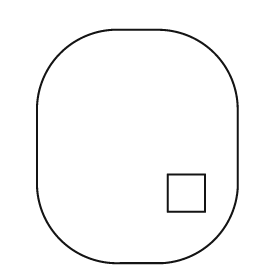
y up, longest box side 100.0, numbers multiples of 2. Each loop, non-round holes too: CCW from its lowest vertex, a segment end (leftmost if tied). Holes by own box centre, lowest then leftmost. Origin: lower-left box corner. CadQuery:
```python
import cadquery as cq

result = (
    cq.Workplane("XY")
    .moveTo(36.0, 0.0)
    .lineTo(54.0, 0.0)
    .threePointArc((76.0, 10.0), (86.0, 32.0))
    .lineTo(86.0, 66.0)
    .threePointArc((76.0, 90.0), (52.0, 100.0))
    .lineTo(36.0, 100.0)
    .threePointArc((10.0, 90.0), (0.0, 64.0))
    .lineTo(0.0, 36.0)
    .threePointArc((10.0, 10.0), (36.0, 0.0))
    .close()
    .moveTo(56.0, 22.0)
    .lineTo(72.0, 22.0)
    .lineTo(72.0, 38.0)
    .lineTo(56.0, 38.0)
    .close()
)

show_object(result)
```